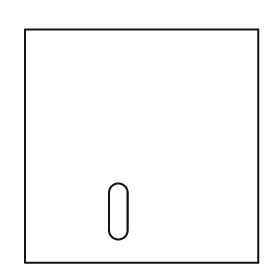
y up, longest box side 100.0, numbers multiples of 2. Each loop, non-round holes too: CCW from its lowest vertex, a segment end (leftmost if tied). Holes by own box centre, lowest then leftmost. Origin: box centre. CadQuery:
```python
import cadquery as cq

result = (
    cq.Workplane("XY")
    .moveTo(-50.0, -50.0)
    .lineTo(50.0, -50.0)
    .lineTo(50.0, 50.0)
    .lineTo(-50.0, 50.0)
    .close()
    .moveTo(-14.0, -36.0)
    .threePointArc((-10.0, -40.0), (-6.0, -36.0))
    .lineTo(-6.0, -20.0)
    .threePointArc((-10.0, -16.0), (-14.0, -20.0))
    .close()
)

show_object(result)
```